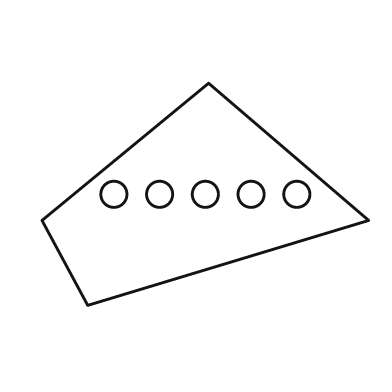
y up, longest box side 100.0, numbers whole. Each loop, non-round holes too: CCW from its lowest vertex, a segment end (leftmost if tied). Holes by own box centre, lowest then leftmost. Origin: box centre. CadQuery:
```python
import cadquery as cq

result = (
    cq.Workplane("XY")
    .moveTo(-36.0, -34.0)
    .lineTo(50.0, -8.0)
    .lineTo(1.0, 34.0)
    .lineTo(-50.0, -8.0)
    .close()
    .moveTo(-28.0, 0.0)
    .circle(4.0)
    .moveTo(-14.0, 0.0)
    .circle(4.0)
    .moveTo(0.0, 0.0)
    .circle(4.0)
    .moveTo(14.0, 0.0)
    .circle(4.0)
    .moveTo(28.0, 0.0)
    .circle(4.0)
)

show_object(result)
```